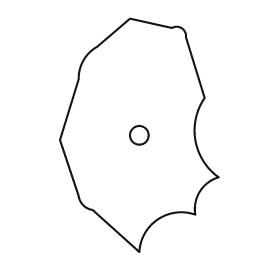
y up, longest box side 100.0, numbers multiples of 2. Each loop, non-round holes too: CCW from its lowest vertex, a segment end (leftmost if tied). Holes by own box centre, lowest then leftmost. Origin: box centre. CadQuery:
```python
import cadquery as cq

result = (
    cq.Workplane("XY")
    .moveTo(0.0, -50.0)
    .threePointArc((8.0, -36.0), (24.0, -34.0))
    .threePointArc((26.0, -24.0), (34.0, -18.0))
    .threePointArc((24.0, -2.0), (28.0, 16.0))
    .lineTo(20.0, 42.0)
    .threePointArc((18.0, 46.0), (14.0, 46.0))
    .lineTo(-4.0, 50.0)
    .lineTo(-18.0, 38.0)
    .threePointArc((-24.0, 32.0), (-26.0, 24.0))
    .lineTo(-34.0, -2.0)
    .lineTo(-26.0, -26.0)
    .threePointArc((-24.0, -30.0), (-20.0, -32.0))
    .close()
    .moveTo(0.0, 0.0)
    .circle(4.0)
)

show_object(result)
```